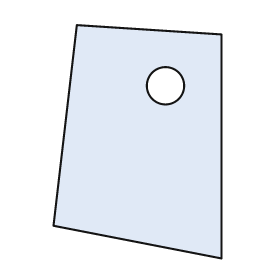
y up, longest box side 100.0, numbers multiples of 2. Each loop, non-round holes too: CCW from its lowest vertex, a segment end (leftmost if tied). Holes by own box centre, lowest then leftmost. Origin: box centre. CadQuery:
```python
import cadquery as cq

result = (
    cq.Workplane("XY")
    .moveTo(36.0, -50.0)
    .lineTo(36.0, 46.0)
    .lineTo(-26.0, 50.0)
    .lineTo(-36.0, -36.0)
    .close()
    .moveTo(12.0, 24.0)
    .circle(8.0)
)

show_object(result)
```